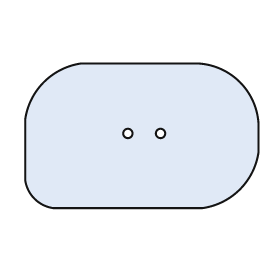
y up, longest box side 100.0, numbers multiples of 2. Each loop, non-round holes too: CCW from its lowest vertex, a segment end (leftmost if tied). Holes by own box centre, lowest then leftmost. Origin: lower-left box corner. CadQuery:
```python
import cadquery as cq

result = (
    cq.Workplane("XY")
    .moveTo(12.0, 0.0)
    .lineTo(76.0, 0.0)
    .threePointArc((92.0, 8.0), (100.0, 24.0))
    .lineTo(100.0, 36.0)
    .threePointArc((92.0, 54.0), (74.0, 62.0))
    .lineTo(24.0, 62.0)
    .threePointArc((8.0, 54.0), (0.0, 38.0))
    .lineTo(0.0, 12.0)
    .threePointArc((4.0, 4.0), (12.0, 0.0))
    .close()
    .moveTo(44.0, 32.0)
    .circle(2.0)
    .moveTo(58.0, 32.0)
    .circle(2.0)
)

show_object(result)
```